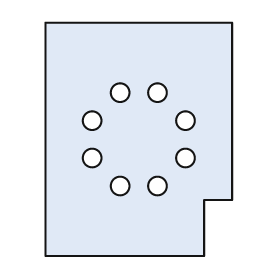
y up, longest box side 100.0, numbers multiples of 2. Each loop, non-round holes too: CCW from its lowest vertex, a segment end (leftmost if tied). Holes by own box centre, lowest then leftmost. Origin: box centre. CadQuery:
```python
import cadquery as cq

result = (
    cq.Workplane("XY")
    .moveTo(-40.0, -50.0)
    .lineTo(28.0, -50.0)
    .lineTo(28.0, -26.0)
    .lineTo(40.0, -26.0)
    .lineTo(40.0, 50.0)
    .lineTo(-40.0, 50.0)
    .close()
    .moveTo(-8.0, -20.0)
    .circle(4.0)
    .moveTo(8.0, -20.0)
    .circle(4.0)
    .moveTo(-20.0, -8.0)
    .circle(4.0)
    .moveTo(20.0, -8.0)
    .circle(4.0)
    .moveTo(-20.0, 8.0)
    .circle(4.0)
    .moveTo(20.0, 8.0)
    .circle(4.0)
    .moveTo(-8.0, 20.0)
    .circle(4.0)
    .moveTo(8.0, 20.0)
    .circle(4.0)
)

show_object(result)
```